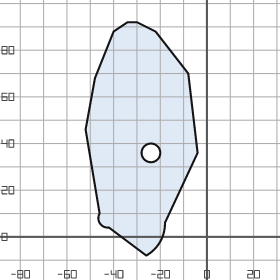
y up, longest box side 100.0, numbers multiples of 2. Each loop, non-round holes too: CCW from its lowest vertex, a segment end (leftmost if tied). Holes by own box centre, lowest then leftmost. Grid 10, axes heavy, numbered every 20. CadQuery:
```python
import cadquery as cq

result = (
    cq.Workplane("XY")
    .moveTo(-26.0, -8.0)
    .threePointArc((-20.0, -2.0), (-18.0, 6.0))
    .lineTo(-4.0, 36.0)
    .lineTo(-8.0, 70.0)
    .lineTo(-22.0, 88.0)
    .lineTo(-30.0, 92.0)
    .lineTo(-34.0, 92.0)
    .lineTo(-40.0, 88.0)
    .lineTo(-48.0, 68.0)
    .lineTo(-52.0, 46.0)
    .lineTo(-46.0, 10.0)
    .threePointArc((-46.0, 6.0), (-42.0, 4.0))
    .close()
    .moveTo(-24.0, 36.0)
    .circle(4.0)
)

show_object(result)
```